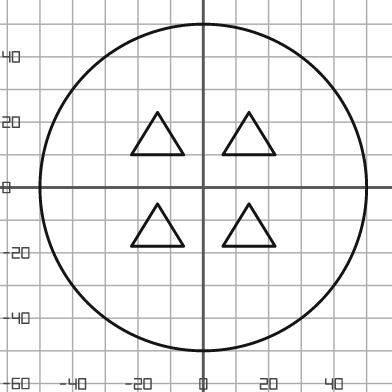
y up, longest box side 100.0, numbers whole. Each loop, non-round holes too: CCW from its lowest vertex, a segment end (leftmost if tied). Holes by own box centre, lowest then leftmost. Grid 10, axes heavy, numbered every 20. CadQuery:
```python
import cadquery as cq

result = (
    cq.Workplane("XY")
    .moveTo(0.0, 0.0)
    .circle(50.0)
    .moveTo(-22.0, -18.0)
    .lineTo(-6.0, -18.0)
    .lineTo(-14.0, -5.0)
    .close()
    .moveTo(6.0, -18.0)
    .lineTo(22.0, -18.0)
    .lineTo(14.0, -5.0)
    .close()
    .moveTo(-22.0, 10.0)
    .lineTo(-6.0, 10.0)
    .lineTo(-14.0, 23.0)
    .close()
    .moveTo(6.0, 10.0)
    .lineTo(22.0, 10.0)
    .lineTo(14.0, 23.0)
    .close()
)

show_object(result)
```